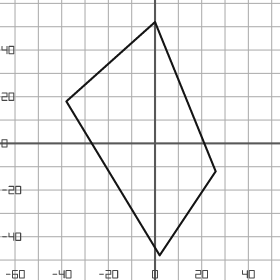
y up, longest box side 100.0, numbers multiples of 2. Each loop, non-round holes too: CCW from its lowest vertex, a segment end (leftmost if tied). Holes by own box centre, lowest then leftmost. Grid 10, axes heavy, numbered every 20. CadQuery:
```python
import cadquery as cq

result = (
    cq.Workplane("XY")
    .moveTo(2.0, -48.0)
    .lineTo(26.0, -12.0)
    .lineTo(0.0, 52.0)
    .lineTo(-38.0, 18.0)
    .close()
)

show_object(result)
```